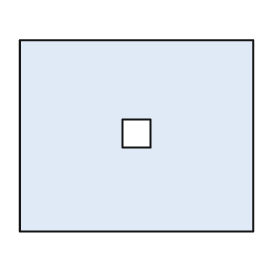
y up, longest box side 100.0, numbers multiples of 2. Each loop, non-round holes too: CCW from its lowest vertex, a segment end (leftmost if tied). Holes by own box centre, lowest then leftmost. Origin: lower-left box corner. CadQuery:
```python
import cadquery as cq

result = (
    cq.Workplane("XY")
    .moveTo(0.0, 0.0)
    .lineTo(100.0, 0.0)
    .lineTo(100.0, 82.0)
    .lineTo(0.0, 82.0)
    .close()
    .moveTo(44.0, 36.0)
    .lineTo(56.0, 36.0)
    .lineTo(56.0, 48.0)
    .lineTo(44.0, 48.0)
    .close()
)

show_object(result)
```